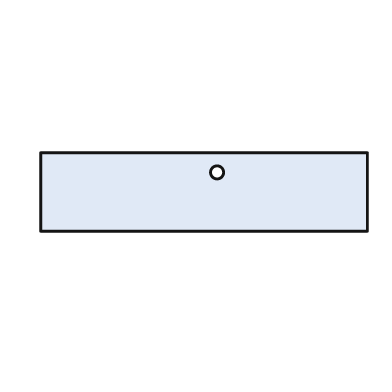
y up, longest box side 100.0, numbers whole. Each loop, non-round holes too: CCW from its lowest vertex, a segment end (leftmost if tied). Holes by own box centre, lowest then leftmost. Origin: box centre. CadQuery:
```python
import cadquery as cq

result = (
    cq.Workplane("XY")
    .moveTo(-50.0, -12.0)
    .lineTo(50.0, -12.0)
    .lineTo(50.0, 12.0)
    .lineTo(-50.0, 12.0)
    .close()
    .moveTo(4.0, 6.0)
    .circle(2.0)
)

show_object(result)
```